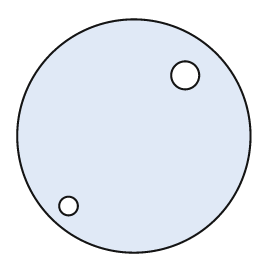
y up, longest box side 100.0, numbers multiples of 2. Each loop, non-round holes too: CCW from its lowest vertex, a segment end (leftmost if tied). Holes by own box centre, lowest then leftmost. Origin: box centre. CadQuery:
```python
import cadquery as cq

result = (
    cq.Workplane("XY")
    .moveTo(0.0, 0.0)
    .circle(50.0)
    .moveTo(-28.0, -30.0)
    .circle(4.0)
    .moveTo(22.0, 26.0)
    .circle(6.0)
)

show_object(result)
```